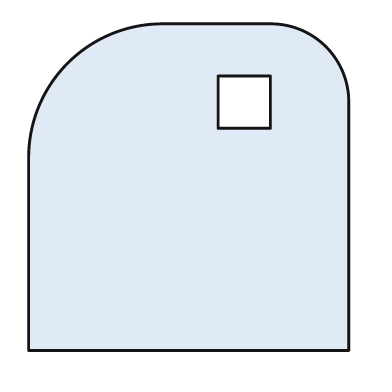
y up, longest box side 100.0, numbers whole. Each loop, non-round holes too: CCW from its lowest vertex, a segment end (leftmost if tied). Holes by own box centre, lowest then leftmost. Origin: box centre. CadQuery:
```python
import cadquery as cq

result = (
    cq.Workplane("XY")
    .moveTo(-49.0, -50.0)
    .lineTo(49.0, -50.0)
    .lineTo(49.0, 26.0)
    .threePointArc((42.0, 43.0), (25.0, 50.0))
    .lineTo(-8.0, 50.0)
    .threePointArc((-37.0, 38.0), (-49.0, 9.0))
    .close()
    .moveTo(9.0, 18.0)
    .lineTo(25.0, 18.0)
    .lineTo(25.0, 34.0)
    .lineTo(9.0, 34.0)
    .close()
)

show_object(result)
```